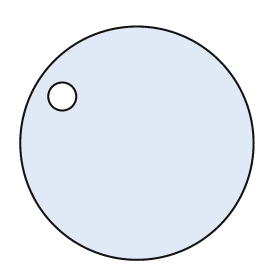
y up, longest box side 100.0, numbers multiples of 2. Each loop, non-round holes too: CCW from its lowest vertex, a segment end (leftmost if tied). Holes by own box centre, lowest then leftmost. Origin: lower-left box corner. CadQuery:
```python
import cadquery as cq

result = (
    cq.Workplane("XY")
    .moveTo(50.0, 50.0)
    .circle(50.0)
    .moveTo(18.0, 70.0)
    .circle(6.0)
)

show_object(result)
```